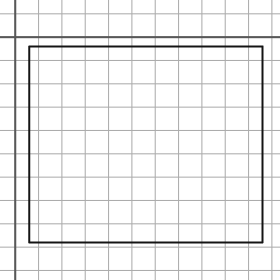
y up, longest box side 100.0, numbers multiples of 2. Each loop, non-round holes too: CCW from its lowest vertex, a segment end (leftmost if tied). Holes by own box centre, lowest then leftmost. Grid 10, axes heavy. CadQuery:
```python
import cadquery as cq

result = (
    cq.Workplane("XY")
    .moveTo(6.0, -88.0)
    .lineTo(106.0, -88.0)
    .lineTo(106.0, -4.0)
    .lineTo(6.0, -4.0)
    .close()
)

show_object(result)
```